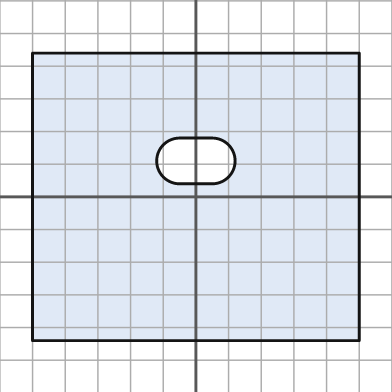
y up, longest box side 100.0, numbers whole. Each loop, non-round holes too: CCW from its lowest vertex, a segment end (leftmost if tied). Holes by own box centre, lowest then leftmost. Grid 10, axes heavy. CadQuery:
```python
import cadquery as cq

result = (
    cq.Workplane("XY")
    .moveTo(-50.0, -44.0)
    .lineTo(50.0, -44.0)
    .lineTo(50.0, 44.0)
    .lineTo(-50.0, 44.0)
    .close()
    .moveTo(-5.0, 4.0)
    .lineTo(5.0, 4.0)
    .threePointArc((12.0, 11.0), (5.0, 18.0))
    .lineTo(-5.0, 18.0)
    .threePointArc((-12.0, 11.0), (-5.0, 4.0))
    .close()
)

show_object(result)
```